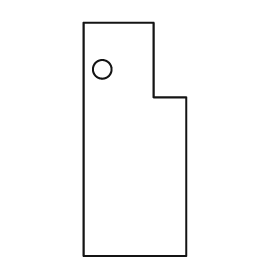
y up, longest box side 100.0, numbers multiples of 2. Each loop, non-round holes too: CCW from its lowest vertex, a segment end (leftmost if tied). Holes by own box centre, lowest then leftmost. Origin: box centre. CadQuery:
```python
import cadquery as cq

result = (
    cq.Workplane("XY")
    .moveTo(-22.0, -50.0)
    .lineTo(22.0, -50.0)
    .lineTo(22.0, 18.0)
    .lineTo(8.0, 18.0)
    .lineTo(8.0, 50.0)
    .lineTo(-22.0, 50.0)
    .close()
    .moveTo(-14.0, 30.0)
    .circle(4.0)
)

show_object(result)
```